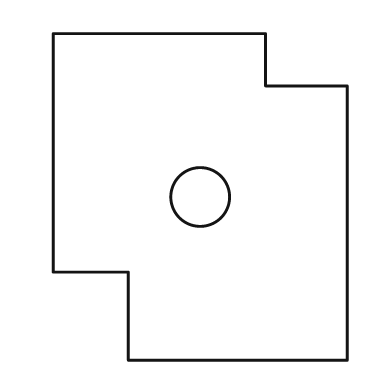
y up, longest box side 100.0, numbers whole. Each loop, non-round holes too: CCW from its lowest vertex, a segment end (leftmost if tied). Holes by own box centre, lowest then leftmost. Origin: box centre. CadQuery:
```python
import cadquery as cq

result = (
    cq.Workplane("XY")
    .moveTo(-22.0, -50.0)
    .lineTo(45.0, -50.0)
    .lineTo(45.0, 34.0)
    .lineTo(20.0, 34.0)
    .lineTo(20.0, 50.0)
    .lineTo(-45.0, 50.0)
    .lineTo(-45.0, -23.0)
    .lineTo(-22.0, -23.0)
    .close()
    .moveTo(0.0, 0.0)
    .circle(9.0)
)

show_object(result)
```